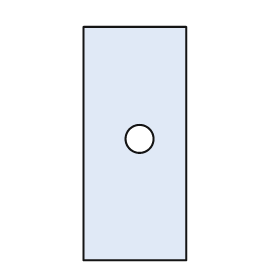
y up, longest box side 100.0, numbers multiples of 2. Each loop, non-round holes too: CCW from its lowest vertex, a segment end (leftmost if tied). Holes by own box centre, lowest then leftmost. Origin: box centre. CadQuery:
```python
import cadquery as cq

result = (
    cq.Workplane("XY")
    .moveTo(-22.0, -50.0)
    .lineTo(22.0, -50.0)
    .lineTo(22.0, 50.0)
    .lineTo(-22.0, 50.0)
    .close()
    .moveTo(2.0, 2.0)
    .circle(6.0)
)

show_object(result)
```